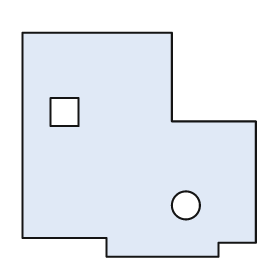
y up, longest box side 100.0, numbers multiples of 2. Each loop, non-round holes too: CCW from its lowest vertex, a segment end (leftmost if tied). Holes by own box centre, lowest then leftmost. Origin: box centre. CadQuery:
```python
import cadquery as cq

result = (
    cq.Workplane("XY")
    .moveTo(-14.0, -48.0)
    .lineTo(34.0, -48.0)
    .lineTo(34.0, -42.0)
    .lineTo(50.0, -42.0)
    .lineTo(50.0, 10.0)
    .lineTo(14.0, 10.0)
    .lineTo(14.0, 48.0)
    .lineTo(-50.0, 48.0)
    .lineTo(-50.0, -40.0)
    .lineTo(-14.0, -40.0)
    .close()
    .moveTo(20.0, -26.0)
    .circle(6.0)
    .moveTo(-38.0, 8.0)
    .lineTo(-26.0, 8.0)
    .lineTo(-26.0, 20.0)
    .lineTo(-38.0, 20.0)
    .close()
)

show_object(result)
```